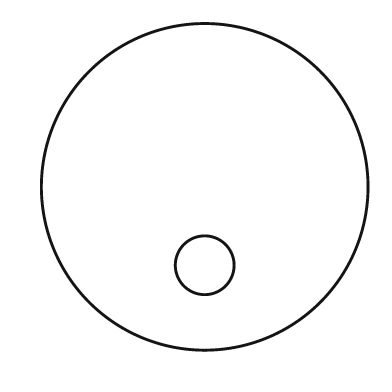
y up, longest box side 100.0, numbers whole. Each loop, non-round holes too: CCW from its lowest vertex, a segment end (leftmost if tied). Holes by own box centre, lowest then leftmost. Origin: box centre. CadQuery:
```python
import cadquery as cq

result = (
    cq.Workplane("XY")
    .moveTo(0.0, 0.0)
    .circle(50.0)
    .moveTo(0.0, -24.0)
    .circle(9.0)
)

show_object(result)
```